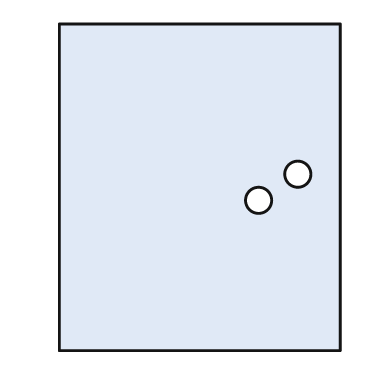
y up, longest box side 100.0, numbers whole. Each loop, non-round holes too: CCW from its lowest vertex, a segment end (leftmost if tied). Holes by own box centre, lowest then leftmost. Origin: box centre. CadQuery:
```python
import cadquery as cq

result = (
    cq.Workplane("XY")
    .moveTo(-43.0, -50.0)
    .lineTo(43.0, -50.0)
    .lineTo(43.0, 50.0)
    .lineTo(-43.0, 50.0)
    .close()
    .moveTo(18.0, -4.0)
    .circle(4.0)
    .moveTo(30.0, 4.0)
    .circle(4.0)
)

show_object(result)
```